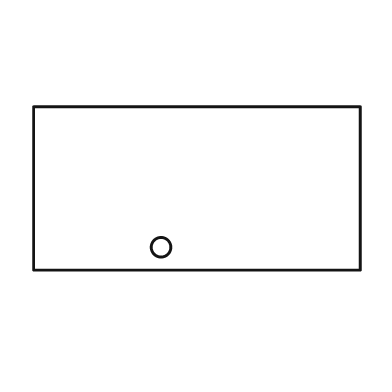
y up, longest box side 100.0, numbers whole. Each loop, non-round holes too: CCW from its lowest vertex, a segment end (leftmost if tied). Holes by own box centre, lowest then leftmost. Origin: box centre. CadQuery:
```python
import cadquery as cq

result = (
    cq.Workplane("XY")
    .moveTo(-50.0, -25.0)
    .lineTo(50.0, -25.0)
    .lineTo(50.0, 25.0)
    .lineTo(-50.0, 25.0)
    .close()
    .moveTo(-11.0, -18.0)
    .circle(3.0)
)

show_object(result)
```